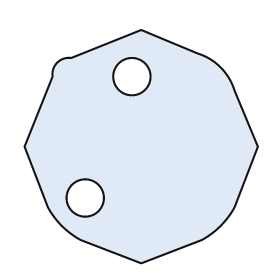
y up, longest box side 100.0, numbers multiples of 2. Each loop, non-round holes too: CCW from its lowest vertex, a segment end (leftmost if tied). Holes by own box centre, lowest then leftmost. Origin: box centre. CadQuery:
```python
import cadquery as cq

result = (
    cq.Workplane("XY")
    .moveTo(0.0, -50.0)
    .lineTo(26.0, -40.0)
    .threePointArc((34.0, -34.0), (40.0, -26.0))
    .lineTo(50.0, 0.0)
    .lineTo(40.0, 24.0)
    .threePointArc((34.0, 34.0), (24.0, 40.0))
    .lineTo(0.0, 50.0)
    .lineTo(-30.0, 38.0)
    .threePointArc((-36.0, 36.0), (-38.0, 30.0))
    .lineTo(-50.0, 0.0)
    .lineTo(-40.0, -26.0)
    .threePointArc((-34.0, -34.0), (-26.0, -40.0))
    .close()
    .moveTo(-24.0, -22.0)
    .circle(8.0)
    .moveTo(-4.0, 30.0)
    .circle(8.0)
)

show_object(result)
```